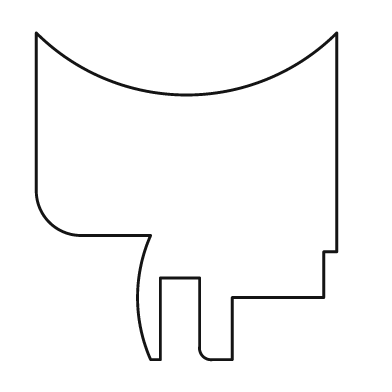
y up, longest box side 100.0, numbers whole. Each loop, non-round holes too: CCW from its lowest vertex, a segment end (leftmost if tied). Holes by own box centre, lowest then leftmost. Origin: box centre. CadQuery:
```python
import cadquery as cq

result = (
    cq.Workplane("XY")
    .moveTo(-11.0, -50.0)
    .lineTo(-8.0, -50.0)
    .lineTo(-8.0, -25.0)
    .lineTo(4.0, -25.0)
    .lineTo(4.0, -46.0)
    .threePointArc((5.0, -49.0), (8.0, -50.0))
    .lineTo(14.0, -50.0)
    .lineTo(14.0, -31.0)
    .lineTo(42.0, -31.0)
    .lineTo(42.0, -17.0)
    .lineTo(46.0, -17.0)
    .lineTo(46.0, 50.0)
    .threePointArc((0.0, 31.0), (-46.0, 50.0))
    .lineTo(-46.0, 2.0)
    .threePointArc((-42.0, -8.0), (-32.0, -12.0))
    .lineTo(-11.0, -12.0)
    .threePointArc((-15.0, -31.0), (-11.0, -50.0))
    .close()
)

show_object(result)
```